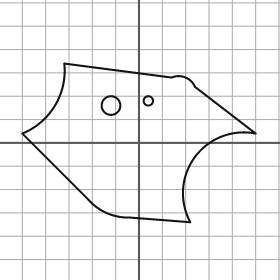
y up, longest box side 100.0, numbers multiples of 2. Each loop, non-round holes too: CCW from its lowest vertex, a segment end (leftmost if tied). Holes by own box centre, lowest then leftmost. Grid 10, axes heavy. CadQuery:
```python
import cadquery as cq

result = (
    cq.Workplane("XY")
    .moveTo(22.0, -34.0)
    .threePointArc((24.0, -6.0), (50.0, 4.0))
    .lineTo(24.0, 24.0)
    .threePointArc((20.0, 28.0), (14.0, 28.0))
    .lineTo(-32.0, 34.0)
    .threePointArc((-36.0, 16.0), (-50.0, 4.0))
    .lineTo(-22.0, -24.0)
    .threePointArc((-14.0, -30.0), (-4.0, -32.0))
    .close()
    .moveTo(-12.0, 16.0)
    .circle(4.0)
    .moveTo(4.0, 18.0)
    .circle(2.0)
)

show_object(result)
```